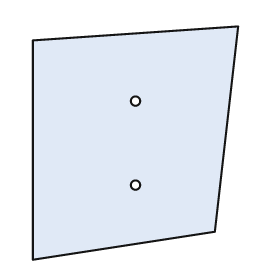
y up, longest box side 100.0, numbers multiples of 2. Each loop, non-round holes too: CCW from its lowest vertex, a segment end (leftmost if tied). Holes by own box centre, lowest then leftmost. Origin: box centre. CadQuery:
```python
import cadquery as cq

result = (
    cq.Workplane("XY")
    .moveTo(-44.0, -50.0)
    .lineTo(34.0, -38.0)
    .lineTo(44.0, 50.0)
    .lineTo(-44.0, 44.0)
    .close()
    .moveTo(0.0, -18.0)
    .circle(2.0)
    .moveTo(0.0, 18.0)
    .circle(2.0)
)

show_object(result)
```